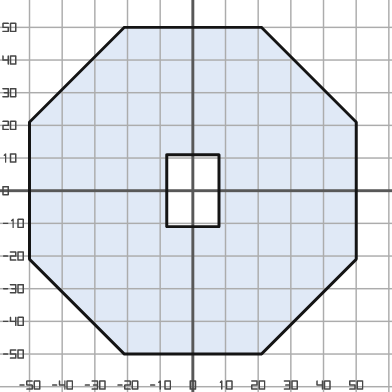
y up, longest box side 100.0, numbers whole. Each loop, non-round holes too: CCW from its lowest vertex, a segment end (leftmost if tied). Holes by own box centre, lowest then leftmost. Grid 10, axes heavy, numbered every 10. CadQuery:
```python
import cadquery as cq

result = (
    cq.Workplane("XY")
    .moveTo(-21.0, -50.0)
    .lineTo(21.0, -50.0)
    .lineTo(50.0, -21.0)
    .lineTo(50.0, 21.0)
    .lineTo(21.0, 50.0)
    .lineTo(-21.0, 50.0)
    .lineTo(-50.0, 21.0)
    .lineTo(-50.0, -21.0)
    .close()
    .moveTo(-8.0, -11.0)
    .lineTo(8.0, -11.0)
    .lineTo(8.0, 11.0)
    .lineTo(-8.0, 11.0)
    .close()
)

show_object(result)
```